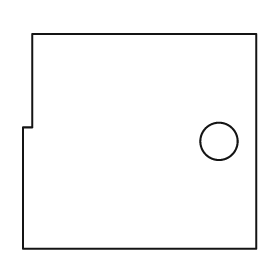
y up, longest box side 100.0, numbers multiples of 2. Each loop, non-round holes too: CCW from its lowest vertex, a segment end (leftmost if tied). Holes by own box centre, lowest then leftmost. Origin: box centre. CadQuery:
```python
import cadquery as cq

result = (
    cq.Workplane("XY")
    .moveTo(-50.0, -46.0)
    .lineTo(50.0, -46.0)
    .lineTo(50.0, 46.0)
    .lineTo(-46.0, 46.0)
    .lineTo(-46.0, 6.0)
    .lineTo(-50.0, 6.0)
    .close()
    .moveTo(34.0, 0.0)
    .circle(8.0)
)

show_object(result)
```